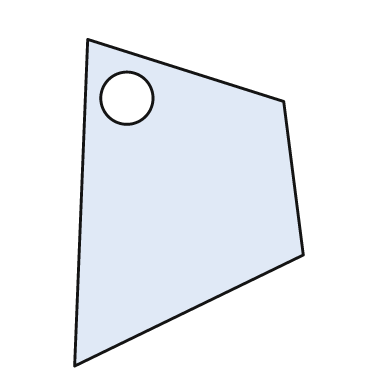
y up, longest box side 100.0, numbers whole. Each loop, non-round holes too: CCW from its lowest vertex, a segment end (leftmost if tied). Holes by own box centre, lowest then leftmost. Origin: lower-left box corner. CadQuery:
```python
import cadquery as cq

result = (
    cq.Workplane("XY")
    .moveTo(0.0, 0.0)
    .lineTo(70.0, 34.0)
    .lineTo(64.0, 81.0)
    .lineTo(4.0, 100.0)
    .close()
    .moveTo(16.0, 82.0)
    .circle(8.0)
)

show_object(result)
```